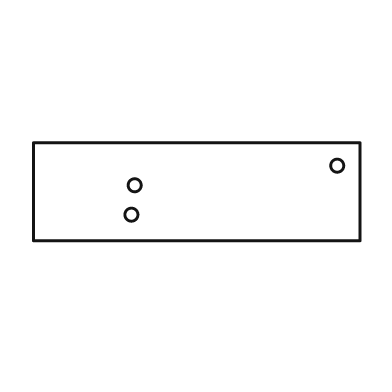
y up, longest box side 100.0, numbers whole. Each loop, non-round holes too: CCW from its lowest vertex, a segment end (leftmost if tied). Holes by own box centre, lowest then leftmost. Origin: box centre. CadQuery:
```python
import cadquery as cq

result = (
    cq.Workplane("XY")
    .moveTo(-50.0, -15.0)
    .lineTo(50.0, -15.0)
    .lineTo(50.0, 15.0)
    .lineTo(-50.0, 15.0)
    .close()
    .moveTo(-20.0, -7.0)
    .circle(2.0)
    .moveTo(-19.0, 2.0)
    .circle(2.0)
    .moveTo(43.0, 8.0)
    .circle(2.0)
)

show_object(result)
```